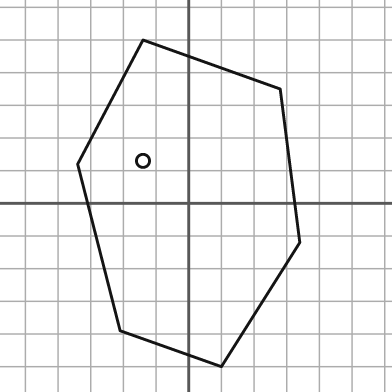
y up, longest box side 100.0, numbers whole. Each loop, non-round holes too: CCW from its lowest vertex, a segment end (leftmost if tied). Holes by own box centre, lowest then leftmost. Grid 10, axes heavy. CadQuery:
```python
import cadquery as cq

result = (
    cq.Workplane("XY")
    .moveTo(10.0, -50.0)
    .lineTo(34.0, -12.0)
    .lineTo(28.0, 35.0)
    .lineTo(-14.0, 50.0)
    .lineTo(-34.0, 12.0)
    .lineTo(-21.0, -39.0)
    .close()
    .moveTo(-14.0, 13.0)
    .circle(2.0)
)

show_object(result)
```